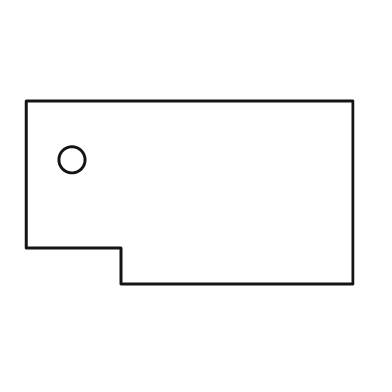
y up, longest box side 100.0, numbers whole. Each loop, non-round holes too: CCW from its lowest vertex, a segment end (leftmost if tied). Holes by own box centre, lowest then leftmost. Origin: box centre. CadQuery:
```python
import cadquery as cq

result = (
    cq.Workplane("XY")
    .moveTo(-21.0, -28.0)
    .lineTo(50.0, -28.0)
    .lineTo(50.0, 28.0)
    .lineTo(-50.0, 28.0)
    .lineTo(-50.0, -17.0)
    .lineTo(-21.0, -17.0)
    .close()
    .moveTo(-36.0, 10.0)
    .circle(4.0)
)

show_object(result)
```